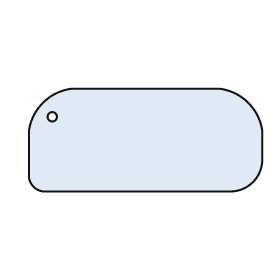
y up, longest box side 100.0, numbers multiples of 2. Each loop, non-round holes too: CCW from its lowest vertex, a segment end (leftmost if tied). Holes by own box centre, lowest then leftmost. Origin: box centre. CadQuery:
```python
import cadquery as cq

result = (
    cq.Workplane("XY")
    .moveTo(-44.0, -22.0)
    .lineTo(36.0, -22.0)
    .threePointArc((46.0, -18.0), (50.0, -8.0))
    .lineTo(50.0, 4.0)
    .threePointArc((44.0, 16.0), (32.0, 22.0))
    .lineTo(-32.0, 22.0)
    .threePointArc((-44.0, 16.0), (-50.0, 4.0))
    .lineTo(-50.0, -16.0)
    .threePointArc((-48.0, -20.0), (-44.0, -22.0))
    .close()
    .moveTo(-40.0, 10.0)
    .circle(2.0)
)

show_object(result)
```